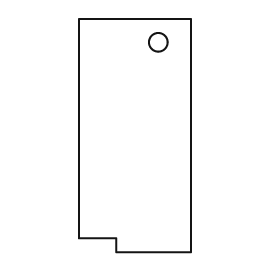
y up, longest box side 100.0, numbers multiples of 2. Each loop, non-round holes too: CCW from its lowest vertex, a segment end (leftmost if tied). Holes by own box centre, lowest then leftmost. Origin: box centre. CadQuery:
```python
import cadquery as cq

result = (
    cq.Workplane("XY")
    .moveTo(-8.0, -50.0)
    .lineTo(24.0, -50.0)
    .lineTo(24.0, 50.0)
    .lineTo(-24.0, 50.0)
    .lineTo(-24.0, -44.0)
    .lineTo(-8.0, -44.0)
    .close()
    .moveTo(10.0, 40.0)
    .circle(4.0)
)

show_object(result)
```